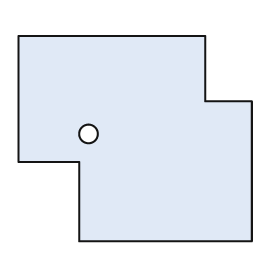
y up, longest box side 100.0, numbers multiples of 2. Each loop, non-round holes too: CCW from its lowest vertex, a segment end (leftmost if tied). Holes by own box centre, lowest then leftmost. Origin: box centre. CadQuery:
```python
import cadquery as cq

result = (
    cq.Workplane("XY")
    .moveTo(-24.0, -44.0)
    .lineTo(50.0, -44.0)
    .lineTo(50.0, 16.0)
    .lineTo(30.0, 16.0)
    .lineTo(30.0, 44.0)
    .lineTo(-50.0, 44.0)
    .lineTo(-50.0, -10.0)
    .lineTo(-24.0, -10.0)
    .close()
    .moveTo(-20.0, 2.0)
    .circle(4.0)
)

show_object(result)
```